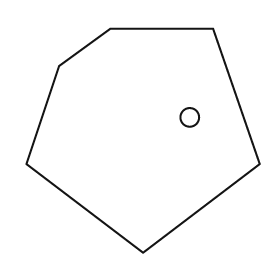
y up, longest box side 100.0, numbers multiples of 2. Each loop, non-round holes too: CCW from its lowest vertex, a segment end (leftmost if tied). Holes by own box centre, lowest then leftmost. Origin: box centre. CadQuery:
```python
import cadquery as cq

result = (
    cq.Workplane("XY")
    .moveTo(0.0, -48.0)
    .lineTo(50.0, -10.0)
    .lineTo(30.0, 48.0)
    .lineTo(-14.0, 48.0)
    .lineTo(-36.0, 32.0)
    .lineTo(-50.0, -10.0)
    .close()
    .moveTo(20.0, 10.0)
    .circle(4.0)
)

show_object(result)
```